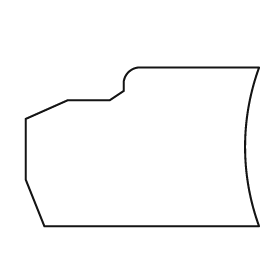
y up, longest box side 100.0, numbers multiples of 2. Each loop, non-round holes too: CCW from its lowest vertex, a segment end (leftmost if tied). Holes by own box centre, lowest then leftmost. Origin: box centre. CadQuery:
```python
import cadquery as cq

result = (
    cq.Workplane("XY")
    .moveTo(-42.0, -34.0)
    .lineTo(50.0, -34.0)
    .threePointArc((44.0, 0.0), (50.0, 34.0))
    .lineTo(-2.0, 34.0)
    .threePointArc((-6.0, 32.0), (-8.0, 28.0))
    .lineTo(-8.0, 24.0)
    .lineTo(-14.0, 20.0)
    .lineTo(-32.0, 20.0)
    .lineTo(-50.0, 12.0)
    .lineTo(-50.0, -14.0)
    .close()
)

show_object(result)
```